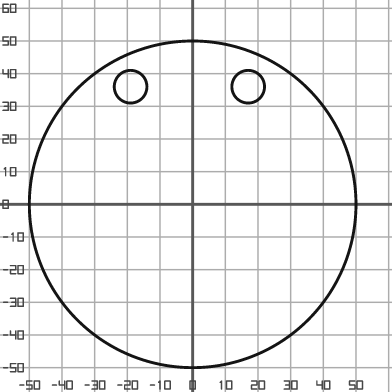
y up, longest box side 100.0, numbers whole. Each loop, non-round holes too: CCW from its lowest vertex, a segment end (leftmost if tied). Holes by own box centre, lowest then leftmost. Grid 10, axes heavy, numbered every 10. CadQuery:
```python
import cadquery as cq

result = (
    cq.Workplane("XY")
    .moveTo(0.0, 0.0)
    .circle(50.0)
    .moveTo(-19.0, 36.0)
    .circle(5.0)
    .moveTo(17.0, 36.0)
    .circle(5.0)
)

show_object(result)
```